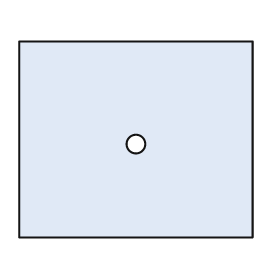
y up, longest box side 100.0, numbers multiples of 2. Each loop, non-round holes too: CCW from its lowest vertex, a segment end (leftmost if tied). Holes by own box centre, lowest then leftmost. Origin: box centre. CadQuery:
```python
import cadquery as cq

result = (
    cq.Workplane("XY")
    .moveTo(-50.0, -42.0)
    .lineTo(50.0, -42.0)
    .lineTo(50.0, 42.0)
    .lineTo(-50.0, 42.0)
    .close()
    .moveTo(0.0, -2.0)
    .circle(4.0)
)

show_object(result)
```